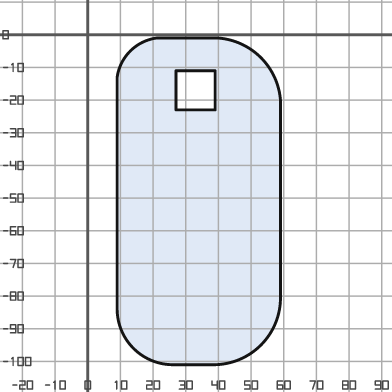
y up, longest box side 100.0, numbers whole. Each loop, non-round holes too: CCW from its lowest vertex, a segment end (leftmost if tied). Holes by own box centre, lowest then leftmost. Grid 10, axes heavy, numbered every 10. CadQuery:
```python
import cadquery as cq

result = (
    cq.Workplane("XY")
    .moveTo(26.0, -101.0)
    .lineTo(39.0, -101.0)
    .threePointArc((53.0, -95.0), (59.0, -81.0))
    .lineTo(59.0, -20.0)
    .threePointArc((53.0, -7.0), (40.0, -1.0))
    .lineTo(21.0, -1.0)
    .threePointArc((13.0, -5.0), (9.0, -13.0))
    .lineTo(9.0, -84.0)
    .threePointArc((14.0, -96.0), (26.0, -101.0))
    .close()
    .moveTo(27.0, -23.0)
    .lineTo(39.0, -23.0)
    .lineTo(39.0, -11.0)
    .lineTo(27.0, -11.0)
    .close()
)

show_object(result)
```